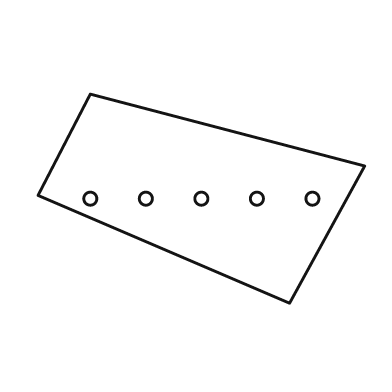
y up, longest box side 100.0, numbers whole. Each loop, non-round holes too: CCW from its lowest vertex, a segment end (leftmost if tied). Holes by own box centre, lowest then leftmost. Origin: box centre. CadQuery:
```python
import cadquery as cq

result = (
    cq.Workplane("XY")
    .moveTo(27.0, -32.0)
    .lineTo(50.0, 10.0)
    .lineTo(-34.0, 32.0)
    .lineTo(-50.0, 1.0)
    .close()
    .moveTo(-34.0, 0.0)
    .circle(2.0)
    .moveTo(-17.0, 0.0)
    .circle(2.0)
    .moveTo(0.0, 0.0)
    .circle(2.0)
    .moveTo(17.0, 0.0)
    .circle(2.0)
    .moveTo(34.0, 0.0)
    .circle(2.0)
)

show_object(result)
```